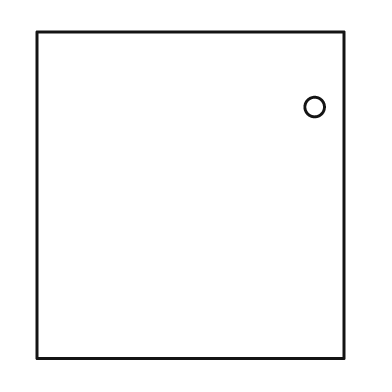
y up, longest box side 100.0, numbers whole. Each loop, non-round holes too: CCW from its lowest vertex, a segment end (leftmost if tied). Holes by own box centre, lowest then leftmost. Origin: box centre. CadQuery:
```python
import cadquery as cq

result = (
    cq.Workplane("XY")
    .moveTo(-47.0, -50.0)
    .lineTo(47.0, -50.0)
    .lineTo(47.0, 50.0)
    .lineTo(-47.0, 50.0)
    .close()
    .moveTo(38.0, 27.0)
    .circle(3.0)
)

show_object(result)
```